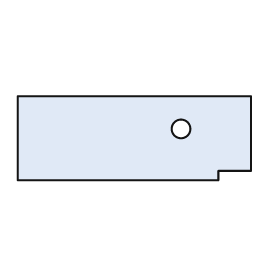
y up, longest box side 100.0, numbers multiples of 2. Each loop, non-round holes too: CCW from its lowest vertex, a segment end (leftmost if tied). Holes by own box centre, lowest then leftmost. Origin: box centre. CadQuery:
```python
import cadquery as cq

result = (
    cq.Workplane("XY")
    .moveTo(-50.0, -18.0)
    .lineTo(36.0, -18.0)
    .lineTo(36.0, -14.0)
    .lineTo(50.0, -14.0)
    .lineTo(50.0, 18.0)
    .lineTo(-50.0, 18.0)
    .close()
    .moveTo(20.0, 4.0)
    .circle(4.0)
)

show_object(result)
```